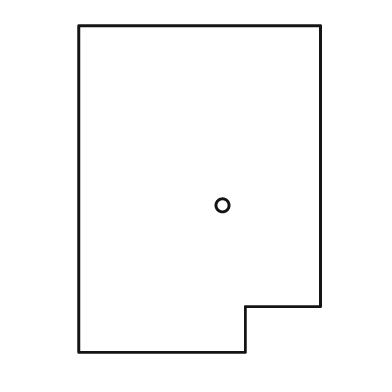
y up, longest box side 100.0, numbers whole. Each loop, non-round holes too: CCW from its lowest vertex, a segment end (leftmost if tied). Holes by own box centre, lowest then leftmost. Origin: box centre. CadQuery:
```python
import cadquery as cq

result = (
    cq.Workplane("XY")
    .moveTo(-37.0, -50.0)
    .lineTo(14.0, -50.0)
    .lineTo(14.0, -36.0)
    .lineTo(37.0, -36.0)
    .lineTo(37.0, 50.0)
    .lineTo(-37.0, 50.0)
    .close()
    .moveTo(7.0, -5.0)
    .circle(2.0)
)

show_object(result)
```